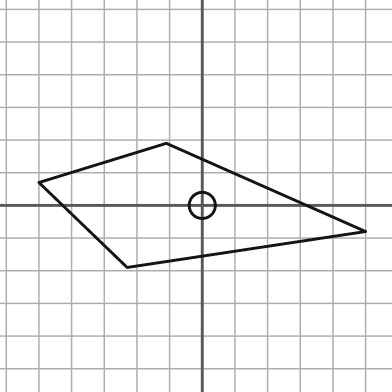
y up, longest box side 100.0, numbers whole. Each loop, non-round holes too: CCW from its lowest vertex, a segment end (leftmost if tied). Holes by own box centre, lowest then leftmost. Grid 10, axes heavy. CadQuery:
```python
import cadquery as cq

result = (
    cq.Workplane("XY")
    .moveTo(-23.0, -19.0)
    .lineTo(50.0, -8.0)
    .lineTo(-11.0, 19.0)
    .lineTo(-50.0, 7.0)
    .close()
    .moveTo(0.0, 0.0)
    .circle(4.0)
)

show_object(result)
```